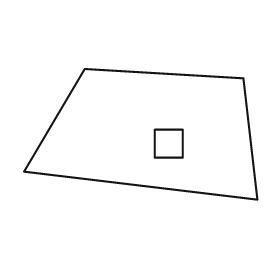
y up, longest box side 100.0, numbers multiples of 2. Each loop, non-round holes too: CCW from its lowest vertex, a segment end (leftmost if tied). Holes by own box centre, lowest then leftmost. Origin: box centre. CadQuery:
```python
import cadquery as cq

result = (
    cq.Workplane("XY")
    .moveTo(50.0, -28.0)
    .lineTo(44.0, 24.0)
    .lineTo(-24.0, 28.0)
    .lineTo(-50.0, -16.0)
    .close()
    .moveTo(6.0, -10.0)
    .lineTo(18.0, -10.0)
    .lineTo(18.0, 2.0)
    .lineTo(6.0, 2.0)
    .close()
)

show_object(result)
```